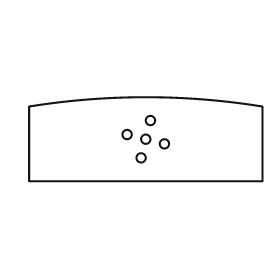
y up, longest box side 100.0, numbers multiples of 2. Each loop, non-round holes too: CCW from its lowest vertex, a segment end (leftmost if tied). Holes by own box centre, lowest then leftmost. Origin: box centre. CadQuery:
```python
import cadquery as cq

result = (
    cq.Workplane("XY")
    .moveTo(-50.0, -18.0)
    .lineTo(50.0, -18.0)
    .lineTo(50.0, 14.0)
    .threePointArc((0.0, 18.0), (-50.0, 14.0))
    .close()
    .moveTo(-2.0, -8.0)
    .circle(2.0)
    .moveTo(8.0, -2.0)
    .circle(2.0)
    .moveTo(0.0, 0.0)
    .circle(2.0)
    .moveTo(-8.0, 2.0)
    .circle(2.0)
    .moveTo(2.0, 8.0)
    .circle(2.0)
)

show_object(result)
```